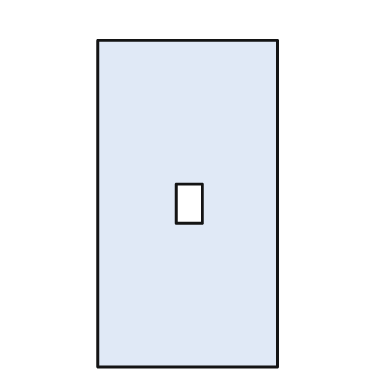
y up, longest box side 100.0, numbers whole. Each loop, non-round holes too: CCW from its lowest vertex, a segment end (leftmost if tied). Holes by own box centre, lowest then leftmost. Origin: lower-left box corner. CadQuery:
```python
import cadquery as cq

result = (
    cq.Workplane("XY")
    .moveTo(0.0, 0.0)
    .lineTo(55.0, 0.0)
    .lineTo(55.0, 100.0)
    .lineTo(0.0, 100.0)
    .close()
    .moveTo(24.0, 44.0)
    .lineTo(32.0, 44.0)
    .lineTo(32.0, 56.0)
    .lineTo(24.0, 56.0)
    .close()
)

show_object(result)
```